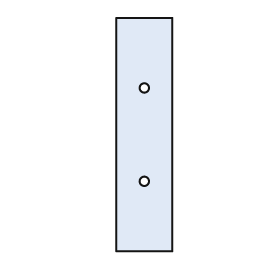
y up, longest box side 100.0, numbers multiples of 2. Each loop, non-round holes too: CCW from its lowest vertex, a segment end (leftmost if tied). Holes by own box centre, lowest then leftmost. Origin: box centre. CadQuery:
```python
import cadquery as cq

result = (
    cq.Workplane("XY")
    .moveTo(-12.0, -50.0)
    .lineTo(12.0, -50.0)
    .lineTo(12.0, 50.0)
    .lineTo(-12.0, 50.0)
    .close()
    .moveTo(0.0, -20.0)
    .circle(2.0)
    .moveTo(0.0, 20.0)
    .circle(2.0)
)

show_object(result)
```